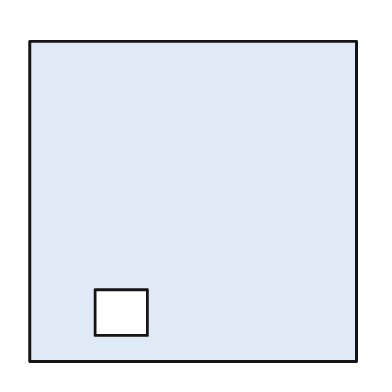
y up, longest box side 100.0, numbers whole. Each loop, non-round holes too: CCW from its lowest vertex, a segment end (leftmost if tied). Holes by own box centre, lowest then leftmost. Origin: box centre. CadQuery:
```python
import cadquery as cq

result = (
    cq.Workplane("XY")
    .moveTo(-50.0, -49.0)
    .lineTo(50.0, -49.0)
    .lineTo(50.0, 49.0)
    .lineTo(-50.0, 49.0)
    .close()
    .moveTo(-30.0, -41.0)
    .lineTo(-14.0, -41.0)
    .lineTo(-14.0, -27.0)
    .lineTo(-30.0, -27.0)
    .close()
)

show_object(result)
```